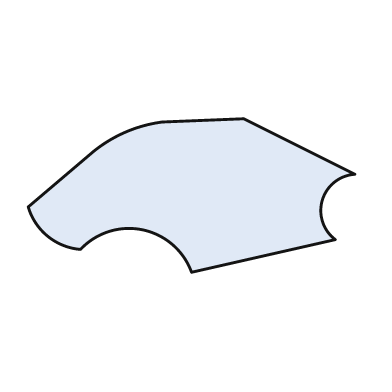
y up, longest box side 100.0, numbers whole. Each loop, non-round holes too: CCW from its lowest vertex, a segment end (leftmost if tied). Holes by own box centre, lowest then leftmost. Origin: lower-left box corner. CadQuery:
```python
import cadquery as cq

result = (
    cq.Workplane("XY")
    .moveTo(50.0, 0.0)
    .lineTo(94.0, 10.0)
    .threePointArc((90.0, 22.0), (100.0, 30.0))
    .lineTo(66.0, 47.0)
    .lineTo(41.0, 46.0)
    .threePointArc((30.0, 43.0), (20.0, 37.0))
    .lineTo(0.0, 20.0)
    .threePointArc((6.0, 11.0), (16.0, 7.0))
    .threePointArc((35.0, 13.0), (50.0, 0.0))
    .close()
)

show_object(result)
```